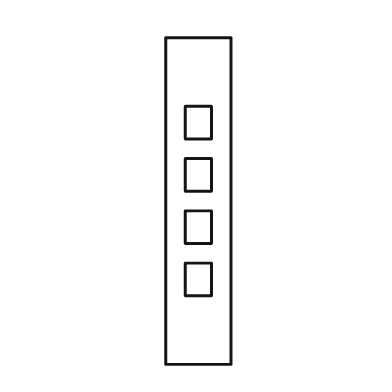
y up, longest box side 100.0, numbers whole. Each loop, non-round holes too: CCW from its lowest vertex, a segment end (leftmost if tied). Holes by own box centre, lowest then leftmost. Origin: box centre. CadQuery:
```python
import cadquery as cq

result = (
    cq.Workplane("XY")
    .moveTo(-10.0, -50.0)
    .lineTo(10.0, -50.0)
    .lineTo(10.0, 50.0)
    .lineTo(-10.0, 50.0)
    .close()
    .moveTo(-4.0, -29.0)
    .lineTo(4.0, -29.0)
    .lineTo(4.0, -19.0)
    .lineTo(-4.0, -19.0)
    .close()
    .moveTo(-4.0, -13.0)
    .lineTo(4.0, -13.0)
    .lineTo(4.0, -3.0)
    .lineTo(-4.0, -3.0)
    .close()
    .moveTo(-4.0, 3.0)
    .lineTo(4.0, 3.0)
    .lineTo(4.0, 13.0)
    .lineTo(-4.0, 13.0)
    .close()
    .moveTo(-4.0, 19.0)
    .lineTo(4.0, 19.0)
    .lineTo(4.0, 29.0)
    .lineTo(-4.0, 29.0)
    .close()
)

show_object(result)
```